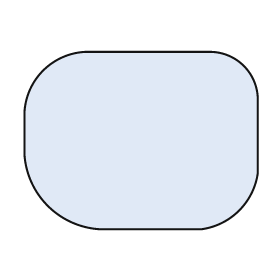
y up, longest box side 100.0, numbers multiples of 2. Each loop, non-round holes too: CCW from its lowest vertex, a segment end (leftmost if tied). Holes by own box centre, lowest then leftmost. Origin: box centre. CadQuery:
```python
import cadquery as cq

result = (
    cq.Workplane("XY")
    .moveTo(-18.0, -38.0)
    .lineTo(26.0, -38.0)
    .threePointArc((42.0, -30.0), (50.0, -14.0))
    .lineTo(50.0, 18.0)
    .threePointArc((44.0, 32.0), (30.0, 38.0))
    .lineTo(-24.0, 38.0)
    .threePointArc((-42.0, 30.0), (-50.0, 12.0))
    .lineTo(-50.0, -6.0)
    .threePointArc((-40.0, -28.0), (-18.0, -38.0))
    .close()
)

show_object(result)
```